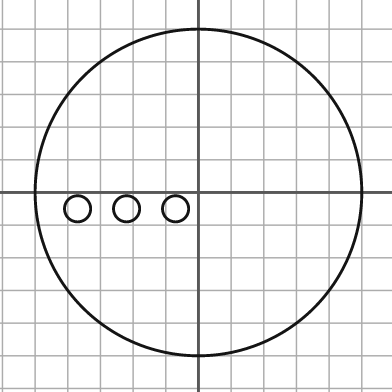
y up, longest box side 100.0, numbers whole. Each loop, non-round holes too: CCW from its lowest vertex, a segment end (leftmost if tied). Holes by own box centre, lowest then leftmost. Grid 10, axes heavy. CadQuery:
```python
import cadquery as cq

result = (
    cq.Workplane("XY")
    .moveTo(0.0, 0.0)
    .circle(50.0)
    .moveTo(-37.0, -5.0)
    .circle(4.0)
    .moveTo(-22.0, -5.0)
    .circle(4.0)
    .moveTo(-7.0, -5.0)
    .circle(4.0)
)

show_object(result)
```